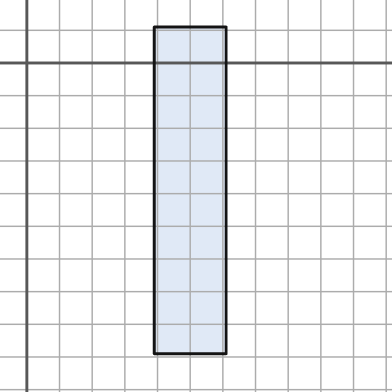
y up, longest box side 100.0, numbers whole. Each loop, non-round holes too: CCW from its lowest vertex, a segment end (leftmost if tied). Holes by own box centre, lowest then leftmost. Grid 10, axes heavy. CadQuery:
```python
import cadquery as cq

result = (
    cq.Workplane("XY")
    .moveTo(39.0, -89.0)
    .lineTo(61.0, -89.0)
    .lineTo(61.0, 11.0)
    .lineTo(39.0, 11.0)
    .close()
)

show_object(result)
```